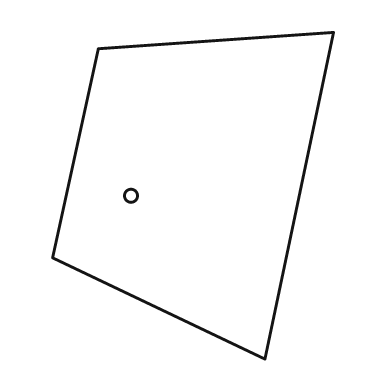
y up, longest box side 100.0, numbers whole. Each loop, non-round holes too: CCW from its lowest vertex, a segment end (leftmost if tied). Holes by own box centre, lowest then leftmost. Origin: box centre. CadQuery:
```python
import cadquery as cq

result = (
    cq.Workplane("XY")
    .moveTo(22.0, -50.0)
    .lineTo(43.0, 50.0)
    .lineTo(-29.0, 45.0)
    .lineTo(-43.0, -19.0)
    .close()
    .moveTo(-19.0, 0.0)
    .circle(2.0)
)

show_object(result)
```